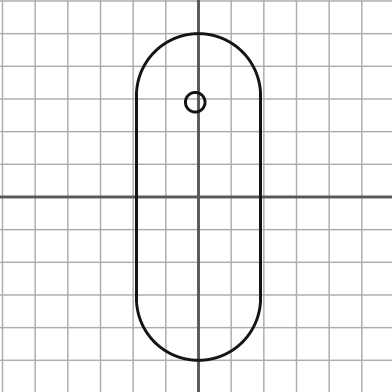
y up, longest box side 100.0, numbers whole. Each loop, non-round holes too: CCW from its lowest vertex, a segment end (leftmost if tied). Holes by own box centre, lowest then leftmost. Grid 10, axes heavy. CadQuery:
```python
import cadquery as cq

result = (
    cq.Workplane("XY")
    .moveTo(-19.0, -31.0)
    .threePointArc((0.0, -50.0), (19.0, -31.0))
    .lineTo(19.0, 31.0)
    .threePointArc((0.0, 50.0), (-19.0, 31.0))
    .close()
    .moveTo(-1.0, 29.0)
    .circle(3.0)
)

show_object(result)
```